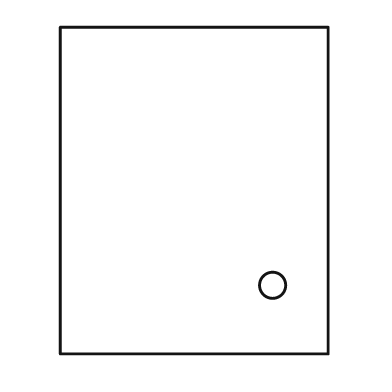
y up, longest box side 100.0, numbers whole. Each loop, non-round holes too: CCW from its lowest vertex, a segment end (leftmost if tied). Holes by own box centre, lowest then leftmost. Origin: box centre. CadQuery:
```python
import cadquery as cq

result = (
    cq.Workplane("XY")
    .moveTo(-41.0, -50.0)
    .lineTo(41.0, -50.0)
    .lineTo(41.0, 50.0)
    .lineTo(-41.0, 50.0)
    .close()
    .moveTo(24.0, -29.0)
    .circle(4.0)
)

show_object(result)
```